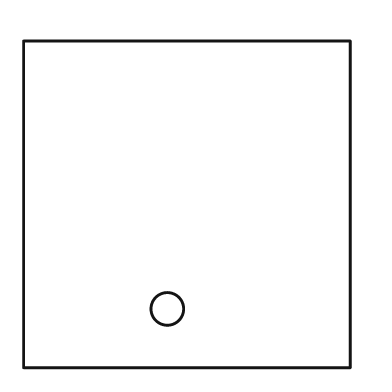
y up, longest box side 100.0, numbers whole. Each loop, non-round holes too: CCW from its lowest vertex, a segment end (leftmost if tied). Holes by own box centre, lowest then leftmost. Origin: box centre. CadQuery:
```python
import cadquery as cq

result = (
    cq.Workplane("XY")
    .moveTo(-50.0, -50.0)
    .lineTo(50.0, -50.0)
    .lineTo(50.0, 50.0)
    .lineTo(-50.0, 50.0)
    .close()
    .moveTo(-6.0, -32.0)
    .circle(5.0)
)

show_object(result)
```